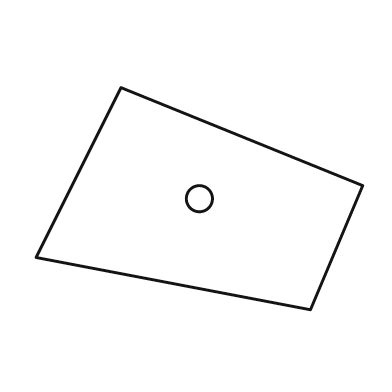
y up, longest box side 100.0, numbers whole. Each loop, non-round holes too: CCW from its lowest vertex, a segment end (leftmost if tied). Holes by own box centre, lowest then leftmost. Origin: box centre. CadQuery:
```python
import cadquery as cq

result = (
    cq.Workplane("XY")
    .moveTo(34.0, -34.0)
    .lineTo(50.0, 4.0)
    .lineTo(-24.0, 34.0)
    .lineTo(-50.0, -18.0)
    .close()
    .moveTo(0.0, 0.0)
    .circle(4.0)
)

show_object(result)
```